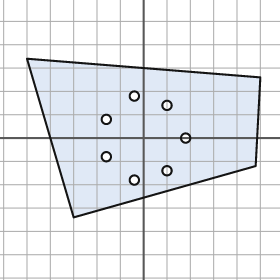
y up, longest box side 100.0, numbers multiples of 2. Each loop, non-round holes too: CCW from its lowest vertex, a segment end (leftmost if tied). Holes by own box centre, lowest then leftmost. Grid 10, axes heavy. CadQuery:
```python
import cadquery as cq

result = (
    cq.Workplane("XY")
    .moveTo(-30.0, -34.0)
    .lineTo(48.0, -12.0)
    .lineTo(50.0, 26.0)
    .lineTo(-50.0, 34.0)
    .close()
    .moveTo(-4.0, -18.0)
    .circle(2.0)
    .moveTo(10.0, -14.0)
    .circle(2.0)
    .moveTo(-16.0, -8.0)
    .circle(2.0)
    .moveTo(18.0, 0.0)
    .circle(2.0)
    .moveTo(-16.0, 8.0)
    .circle(2.0)
    .moveTo(10.0, 14.0)
    .circle(2.0)
    .moveTo(-4.0, 18.0)
    .circle(2.0)
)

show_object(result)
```